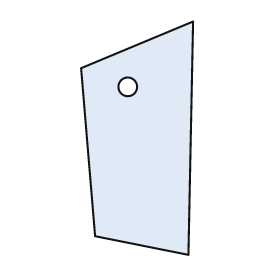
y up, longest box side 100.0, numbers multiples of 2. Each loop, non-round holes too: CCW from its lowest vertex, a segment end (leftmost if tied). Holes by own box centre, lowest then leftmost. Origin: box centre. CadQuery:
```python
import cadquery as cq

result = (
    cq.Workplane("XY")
    .moveTo(22.0, -50.0)
    .lineTo(24.0, 50.0)
    .lineTo(-24.0, 30.0)
    .lineTo(-18.0, -42.0)
    .close()
    .moveTo(-4.0, 22.0)
    .circle(4.0)
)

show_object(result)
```